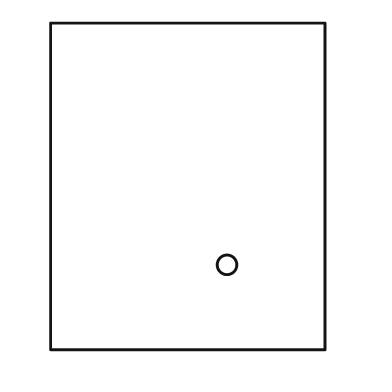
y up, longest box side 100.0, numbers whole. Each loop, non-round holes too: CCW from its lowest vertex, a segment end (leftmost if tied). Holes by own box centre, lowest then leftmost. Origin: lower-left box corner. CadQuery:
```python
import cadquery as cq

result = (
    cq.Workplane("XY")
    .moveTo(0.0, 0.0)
    .lineTo(84.0, 0.0)
    .lineTo(84.0, 100.0)
    .lineTo(0.0, 100.0)
    .close()
    .moveTo(54.0, 26.0)
    .circle(3.0)
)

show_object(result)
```